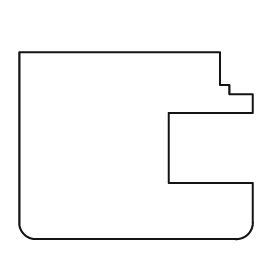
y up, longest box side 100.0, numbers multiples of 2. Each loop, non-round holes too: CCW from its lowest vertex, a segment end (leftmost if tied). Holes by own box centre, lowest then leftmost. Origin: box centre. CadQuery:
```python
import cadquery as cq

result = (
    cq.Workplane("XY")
    .moveTo(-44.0, -40.0)
    .lineTo(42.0, -40.0)
    .threePointArc((48.0, -38.0), (50.0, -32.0))
    .lineTo(50.0, -16.0)
    .lineTo(14.0, -16.0)
    .lineTo(14.0, 14.0)
    .lineTo(50.0, 14.0)
    .lineTo(50.0, 22.0)
    .lineTo(40.0, 22.0)
    .lineTo(40.0, 26.0)
    .lineTo(36.0, 26.0)
    .lineTo(36.0, 40.0)
    .lineTo(-50.0, 40.0)
    .lineTo(-50.0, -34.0)
    .threePointArc((-48.0, -38.0), (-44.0, -40.0))
    .close()
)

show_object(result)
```